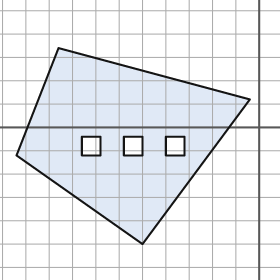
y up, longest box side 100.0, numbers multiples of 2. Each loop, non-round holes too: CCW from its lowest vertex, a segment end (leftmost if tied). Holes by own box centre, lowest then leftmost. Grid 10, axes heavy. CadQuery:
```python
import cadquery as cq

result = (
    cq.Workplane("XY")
    .moveTo(-50.0, -50.0)
    .lineTo(-4.0, 12.0)
    .lineTo(-86.0, 34.0)
    .lineTo(-104.0, -12.0)
    .close()
    .moveTo(-76.0, -12.0)
    .lineTo(-68.0, -12.0)
    .lineTo(-68.0, -4.0)
    .lineTo(-76.0, -4.0)
    .close()
    .moveTo(-58.0, -12.0)
    .lineTo(-50.0, -12.0)
    .lineTo(-50.0, -4.0)
    .lineTo(-58.0, -4.0)
    .close()
    .moveTo(-40.0, -12.0)
    .lineTo(-32.0, -12.0)
    .lineTo(-32.0, -4.0)
    .lineTo(-40.0, -4.0)
    .close()
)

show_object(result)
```